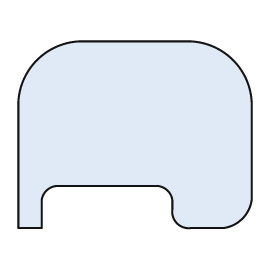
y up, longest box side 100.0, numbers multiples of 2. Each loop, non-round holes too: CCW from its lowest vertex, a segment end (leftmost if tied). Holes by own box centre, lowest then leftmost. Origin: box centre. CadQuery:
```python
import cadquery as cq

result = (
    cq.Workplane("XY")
    .moveTo(-50.0, -40.0)
    .lineTo(-40.0, -40.0)
    .lineTo(-40.0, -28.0)
    .threePointArc((-38.0, -24.0), (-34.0, -22.0))
    .lineTo(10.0, -22.0)
    .threePointArc((14.0, -24.0), (16.0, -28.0))
    .lineTo(16.0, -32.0)
    .threePointArc((18.0, -38.0), (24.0, -40.0))
    .lineTo(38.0, -40.0)
    .threePointArc((46.0, -36.0), (50.0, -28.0))
    .lineTo(50.0, 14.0)
    .threePointArc((42.0, 32.0), (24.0, 40.0))
    .lineTo(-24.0, 40.0)
    .threePointArc((-42.0, 32.0), (-50.0, 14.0))
    .close()
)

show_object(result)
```